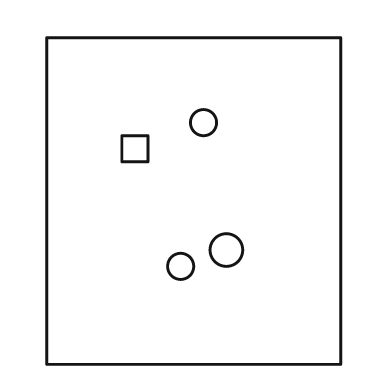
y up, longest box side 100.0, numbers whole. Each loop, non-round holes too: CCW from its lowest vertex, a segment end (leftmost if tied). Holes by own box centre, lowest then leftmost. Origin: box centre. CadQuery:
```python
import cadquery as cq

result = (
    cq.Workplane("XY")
    .moveTo(-45.0, -50.0)
    .lineTo(45.0, -50.0)
    .lineTo(45.0, 50.0)
    .lineTo(-45.0, 50.0)
    .close()
    .moveTo(-4.0, -20.0)
    .circle(4.0)
    .moveTo(10.0, -15.0)
    .circle(5.0)
    .moveTo(-22.0, 12.0)
    .lineTo(-14.0, 12.0)
    .lineTo(-14.0, 20.0)
    .lineTo(-22.0, 20.0)
    .close()
    .moveTo(3.0, 24.0)
    .circle(4.0)
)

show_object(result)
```